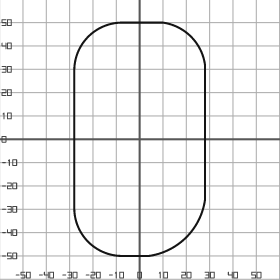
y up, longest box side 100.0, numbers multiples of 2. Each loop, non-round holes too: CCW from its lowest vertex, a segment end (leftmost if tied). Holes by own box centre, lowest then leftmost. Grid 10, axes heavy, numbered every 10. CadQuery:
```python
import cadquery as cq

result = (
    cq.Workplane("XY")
    .moveTo(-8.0, -50.0)
    .lineTo(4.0, -50.0)
    .threePointArc((20.0, -42.0), (28.0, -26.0))
    .lineTo(28.0, 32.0)
    .threePointArc((22.0, 44.0), (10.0, 50.0))
    .lineTo(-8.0, 50.0)
    .threePointArc((-22.0, 44.0), (-28.0, 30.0))
    .lineTo(-28.0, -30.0)
    .threePointArc((-22.0, -44.0), (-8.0, -50.0))
    .close()
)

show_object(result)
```